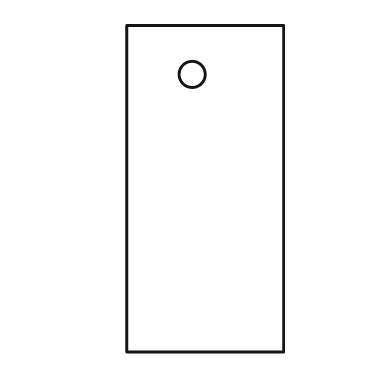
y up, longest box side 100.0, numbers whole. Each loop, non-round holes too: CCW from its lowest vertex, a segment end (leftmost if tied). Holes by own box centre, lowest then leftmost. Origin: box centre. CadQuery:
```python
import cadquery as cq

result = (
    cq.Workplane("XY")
    .moveTo(-24.0, -50.0)
    .lineTo(24.0, -50.0)
    .lineTo(24.0, 50.0)
    .lineTo(-24.0, 50.0)
    .close()
    .moveTo(-4.0, 35.0)
    .circle(4.0)
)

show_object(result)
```